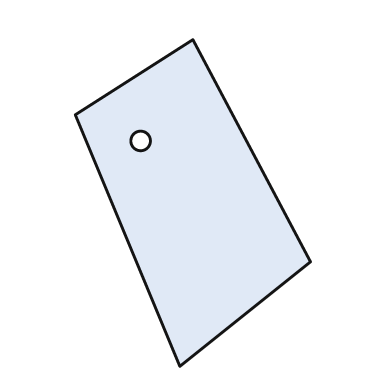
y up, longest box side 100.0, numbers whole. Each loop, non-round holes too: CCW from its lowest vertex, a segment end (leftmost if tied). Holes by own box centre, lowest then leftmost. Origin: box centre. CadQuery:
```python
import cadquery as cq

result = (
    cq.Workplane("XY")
    .moveTo(-4.0, -50.0)
    .lineTo(36.0, -18.0)
    .lineTo(0.0, 50.0)
    .lineTo(-36.0, 27.0)
    .close()
    .moveTo(-16.0, 19.0)
    .circle(3.0)
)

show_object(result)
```